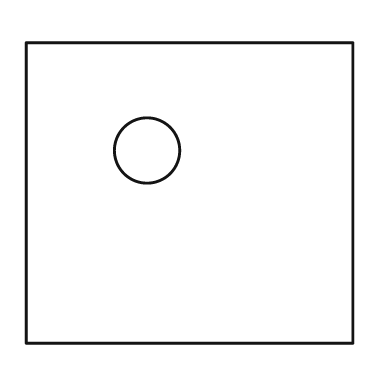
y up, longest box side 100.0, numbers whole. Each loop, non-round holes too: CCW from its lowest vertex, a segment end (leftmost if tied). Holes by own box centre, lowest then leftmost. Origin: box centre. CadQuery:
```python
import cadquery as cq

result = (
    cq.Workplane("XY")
    .moveTo(-50.0, -46.0)
    .lineTo(50.0, -46.0)
    .lineTo(50.0, 46.0)
    .lineTo(-50.0, 46.0)
    .close()
    .moveTo(-13.0, 13.0)
    .circle(10.0)
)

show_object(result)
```